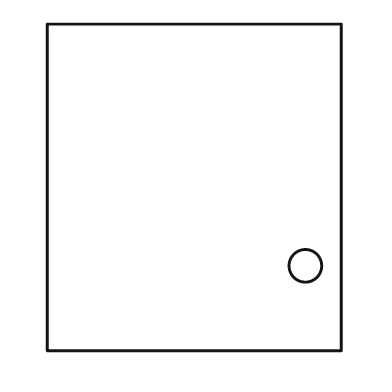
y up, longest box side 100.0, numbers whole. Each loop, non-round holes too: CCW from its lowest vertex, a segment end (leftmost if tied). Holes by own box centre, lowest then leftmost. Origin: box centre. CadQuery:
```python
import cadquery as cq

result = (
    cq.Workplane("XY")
    .moveTo(-45.0, -50.0)
    .lineTo(45.0, -50.0)
    .lineTo(45.0, 50.0)
    .lineTo(-45.0, 50.0)
    .close()
    .moveTo(34.0, -24.0)
    .circle(5.0)
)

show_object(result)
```